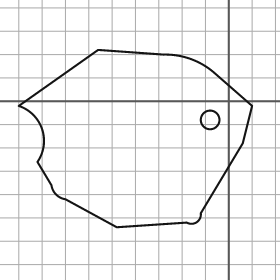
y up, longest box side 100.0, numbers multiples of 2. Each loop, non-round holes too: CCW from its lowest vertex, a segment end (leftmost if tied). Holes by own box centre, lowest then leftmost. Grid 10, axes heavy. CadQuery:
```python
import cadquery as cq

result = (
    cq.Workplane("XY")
    .moveTo(-48.0, -54.0)
    .lineTo(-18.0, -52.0)
    .threePointArc((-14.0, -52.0), (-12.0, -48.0))
    .lineTo(6.0, -18.0)
    .lineTo(10.0, -2.0)
    .lineTo(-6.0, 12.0)
    .threePointArc((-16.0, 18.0), (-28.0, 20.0))
    .lineTo(-56.0, 22.0)
    .lineTo(-90.0, -2.0)
    .threePointArc((-80.0, -12.0), (-82.0, -26.0))
    .lineTo(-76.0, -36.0)
    .threePointArc((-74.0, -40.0), (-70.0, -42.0))
    .close()
    .moveTo(-8.0, -8.0)
    .circle(4.0)
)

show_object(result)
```